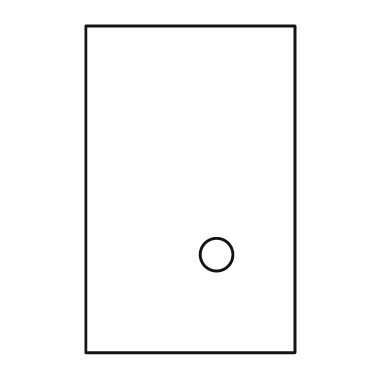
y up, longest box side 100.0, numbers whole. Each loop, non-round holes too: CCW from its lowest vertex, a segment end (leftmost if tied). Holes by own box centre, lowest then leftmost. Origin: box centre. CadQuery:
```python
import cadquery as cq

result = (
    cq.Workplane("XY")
    .moveTo(-32.0, -50.0)
    .lineTo(32.0, -50.0)
    .lineTo(32.0, 50.0)
    .lineTo(-32.0, 50.0)
    .close()
    .moveTo(8.0, -20.0)
    .circle(5.0)
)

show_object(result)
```